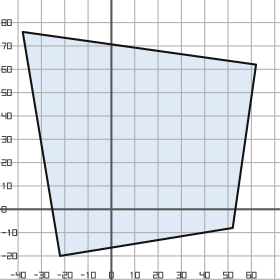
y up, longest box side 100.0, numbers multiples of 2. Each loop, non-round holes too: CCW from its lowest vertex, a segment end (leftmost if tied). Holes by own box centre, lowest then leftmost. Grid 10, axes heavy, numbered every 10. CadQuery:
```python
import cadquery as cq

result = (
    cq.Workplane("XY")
    .moveTo(-22.0, -20.0)
    .lineTo(52.0, -8.0)
    .lineTo(62.0, 62.0)
    .lineTo(-38.0, 76.0)
    .close()
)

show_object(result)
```